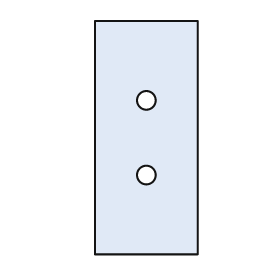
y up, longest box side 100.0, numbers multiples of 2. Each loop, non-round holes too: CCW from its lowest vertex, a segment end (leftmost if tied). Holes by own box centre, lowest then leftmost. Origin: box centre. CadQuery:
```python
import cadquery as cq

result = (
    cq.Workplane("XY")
    .moveTo(-22.0, -50.0)
    .lineTo(22.0, -50.0)
    .lineTo(22.0, 50.0)
    .lineTo(-22.0, 50.0)
    .close()
    .moveTo(0.0, -16.0)
    .circle(4.0)
    .moveTo(0.0, 16.0)
    .circle(4.0)
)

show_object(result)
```